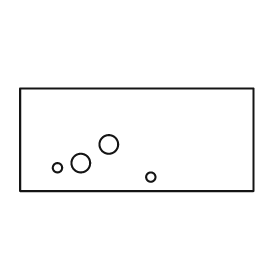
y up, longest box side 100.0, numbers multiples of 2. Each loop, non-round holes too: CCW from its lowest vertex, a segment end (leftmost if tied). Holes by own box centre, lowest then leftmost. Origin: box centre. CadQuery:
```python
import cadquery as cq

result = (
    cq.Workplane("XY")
    .moveTo(-50.0, -22.0)
    .lineTo(50.0, -22.0)
    .lineTo(50.0, 22.0)
    .lineTo(-50.0, 22.0)
    .close()
    .moveTo(6.0, -16.0)
    .circle(2.0)
    .moveTo(-34.0, -12.0)
    .circle(2.0)
    .moveTo(-24.0, -10.0)
    .circle(4.0)
    .moveTo(-12.0, -2.0)
    .circle(4.0)
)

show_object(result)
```